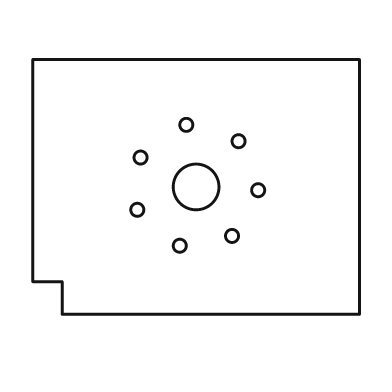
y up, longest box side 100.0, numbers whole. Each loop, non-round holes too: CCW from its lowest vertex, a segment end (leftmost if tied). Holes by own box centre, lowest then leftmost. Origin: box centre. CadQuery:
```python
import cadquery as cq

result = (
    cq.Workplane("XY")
    .moveTo(-41.0, -39.0)
    .lineTo(50.0, -39.0)
    .lineTo(50.0, 39.0)
    .lineTo(-50.0, 39.0)
    .lineTo(-50.0, -29.0)
    .lineTo(-41.0, -29.0)
    .close()
    .moveTo(-5.0, -18.0)
    .circle(2.0)
    .moveTo(11.0, -15.0)
    .circle(2.0)
    .moveTo(-18.0, -7.0)
    .circle(2.0)
    .moveTo(19.0, -1.0)
    .circle(2.0)
    .moveTo(0.0, 0.0)
    .circle(7.0)
    .moveTo(-17.0, 9.0)
    .circle(2.0)
    .moveTo(13.0, 14.0)
    .circle(2.0)
    .moveTo(-3.0, 19.0)
    .circle(2.0)
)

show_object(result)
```